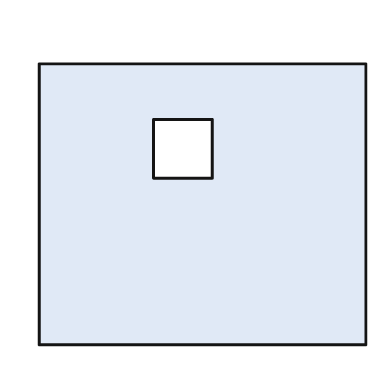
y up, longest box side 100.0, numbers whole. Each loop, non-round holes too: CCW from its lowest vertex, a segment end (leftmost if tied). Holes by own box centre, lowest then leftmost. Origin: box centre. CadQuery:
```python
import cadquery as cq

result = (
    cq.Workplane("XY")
    .moveTo(-50.0, -43.0)
    .lineTo(50.0, -43.0)
    .lineTo(50.0, 43.0)
    .lineTo(-50.0, 43.0)
    .close()
    .moveTo(-15.0, 8.0)
    .lineTo(3.0, 8.0)
    .lineTo(3.0, 26.0)
    .lineTo(-15.0, 26.0)
    .close()
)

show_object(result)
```